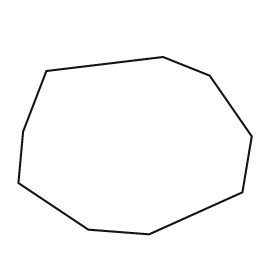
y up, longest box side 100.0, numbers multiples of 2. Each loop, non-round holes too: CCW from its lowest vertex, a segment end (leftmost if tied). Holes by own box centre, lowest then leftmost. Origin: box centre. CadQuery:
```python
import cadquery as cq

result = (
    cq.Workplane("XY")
    .moveTo(6.0, -38.0)
    .lineTo(46.0, -20.0)
    .lineTo(50.0, 4.0)
    .lineTo(32.0, 30.0)
    .lineTo(12.0, 38.0)
    .lineTo(-38.0, 32.0)
    .lineTo(-48.0, 6.0)
    .lineTo(-50.0, -16.0)
    .lineTo(-20.0, -36.0)
    .close()
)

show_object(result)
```